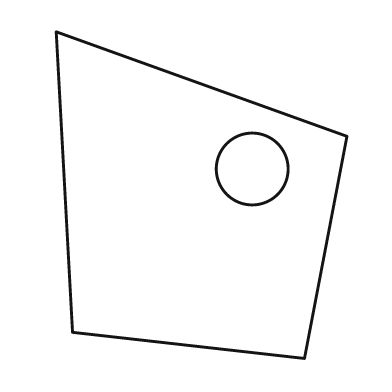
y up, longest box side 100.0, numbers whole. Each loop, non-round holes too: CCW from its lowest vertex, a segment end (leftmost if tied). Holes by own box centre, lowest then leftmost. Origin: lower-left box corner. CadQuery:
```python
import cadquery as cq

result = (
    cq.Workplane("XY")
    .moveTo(76.0, 0.0)
    .lineTo(89.0, 68.0)
    .lineTo(0.0, 100.0)
    .lineTo(5.0, 8.0)
    .close()
    .moveTo(60.0, 58.0)
    .circle(11.0)
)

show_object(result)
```